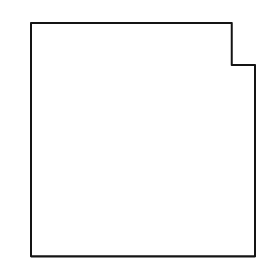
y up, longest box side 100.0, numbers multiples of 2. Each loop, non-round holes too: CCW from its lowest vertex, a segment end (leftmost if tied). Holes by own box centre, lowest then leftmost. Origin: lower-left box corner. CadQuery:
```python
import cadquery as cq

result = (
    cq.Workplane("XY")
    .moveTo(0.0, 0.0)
    .lineTo(96.0, 0.0)
    .lineTo(96.0, 82.0)
    .lineTo(86.0, 82.0)
    .lineTo(86.0, 100.0)
    .lineTo(0.0, 100.0)
    .close()
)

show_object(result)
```